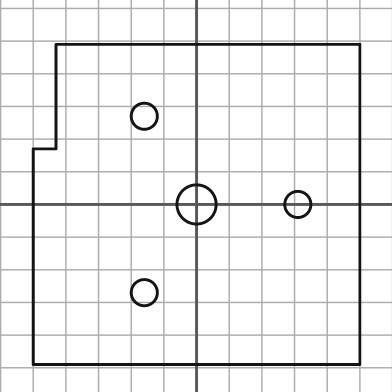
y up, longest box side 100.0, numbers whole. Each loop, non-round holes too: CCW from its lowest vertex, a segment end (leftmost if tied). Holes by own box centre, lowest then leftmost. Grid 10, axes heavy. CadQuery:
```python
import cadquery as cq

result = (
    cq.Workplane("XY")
    .moveTo(-50.0, -49.0)
    .lineTo(50.0, -49.0)
    .lineTo(50.0, 49.0)
    .lineTo(-43.0, 49.0)
    .lineTo(-43.0, 17.0)
    .lineTo(-50.0, 17.0)
    .close()
    .moveTo(-16.0, -27.0)
    .circle(4.0)
    .moveTo(0.0, 0.0)
    .circle(6.0)
    .moveTo(31.0, 0.0)
    .circle(4.0)
    .moveTo(-16.0, 27.0)
    .circle(4.0)
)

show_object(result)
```